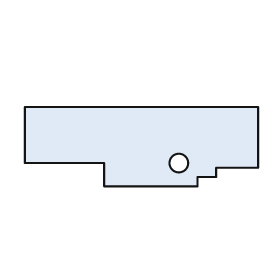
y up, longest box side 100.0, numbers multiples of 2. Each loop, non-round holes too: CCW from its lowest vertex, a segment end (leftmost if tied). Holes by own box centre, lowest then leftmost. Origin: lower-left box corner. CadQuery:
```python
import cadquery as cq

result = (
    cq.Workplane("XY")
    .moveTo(34.0, 0.0)
    .lineTo(74.0, 0.0)
    .lineTo(74.0, 4.0)
    .lineTo(82.0, 4.0)
    .lineTo(82.0, 8.0)
    .lineTo(100.0, 8.0)
    .lineTo(100.0, 34.0)
    .lineTo(0.0, 34.0)
    .lineTo(0.0, 10.0)
    .lineTo(34.0, 10.0)
    .close()
    .moveTo(66.0, 10.0)
    .circle(4.0)
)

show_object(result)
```